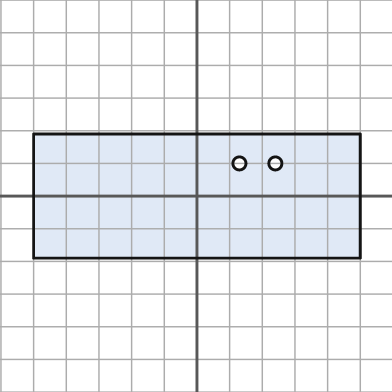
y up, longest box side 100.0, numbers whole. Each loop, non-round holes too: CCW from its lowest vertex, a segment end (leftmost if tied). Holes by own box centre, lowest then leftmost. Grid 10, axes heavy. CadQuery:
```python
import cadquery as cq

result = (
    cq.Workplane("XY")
    .moveTo(-50.0, -19.0)
    .lineTo(50.0, -19.0)
    .lineTo(50.0, 19.0)
    .lineTo(-50.0, 19.0)
    .close()
    .moveTo(13.0, 10.0)
    .circle(2.0)
    .moveTo(24.0, 10.0)
    .circle(2.0)
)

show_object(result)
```